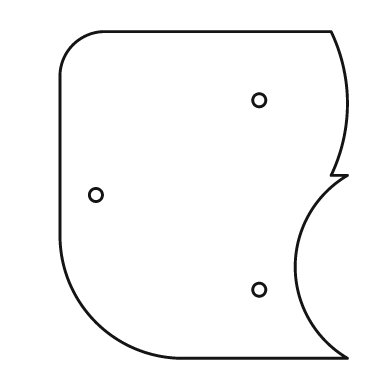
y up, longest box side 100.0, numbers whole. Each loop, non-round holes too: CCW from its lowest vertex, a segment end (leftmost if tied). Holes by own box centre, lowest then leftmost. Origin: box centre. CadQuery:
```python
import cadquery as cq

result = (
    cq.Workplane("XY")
    .moveTo(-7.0, -50.0)
    .lineTo(44.0, -50.0)
    .threePointArc((28.0, -22.0), (44.0, 6.0))
    .lineTo(39.0, 6.0)
    .threePointArc((44.0, 28.0), (39.0, 50.0))
    .lineTo(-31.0, 50.0)
    .threePointArc((-40.0, 46.0), (-44.0, 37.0))
    .lineTo(-44.0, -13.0)
    .threePointArc((-33.0, -39.0), (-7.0, -50.0))
    .close()
    .moveTo(17.0, -29.0)
    .circle(2.0)
    .moveTo(-33.0, 0.0)
    .circle(2.0)
    .moveTo(17.0, 29.0)
    .circle(2.0)
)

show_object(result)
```